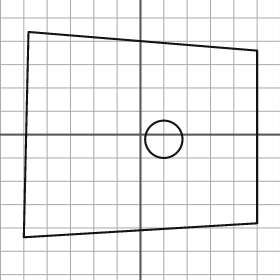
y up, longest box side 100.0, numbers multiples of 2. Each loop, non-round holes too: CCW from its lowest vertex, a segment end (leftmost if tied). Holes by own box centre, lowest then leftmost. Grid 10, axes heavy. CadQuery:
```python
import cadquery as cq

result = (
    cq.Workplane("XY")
    .moveTo(-50.0, -44.0)
    .lineTo(50.0, -38.0)
    .lineTo(50.0, 36.0)
    .lineTo(-48.0, 44.0)
    .close()
    .moveTo(10.0, -2.0)
    .circle(8.0)
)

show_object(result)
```